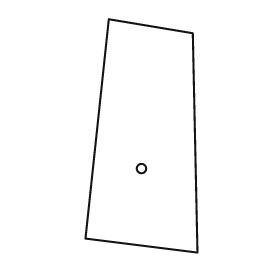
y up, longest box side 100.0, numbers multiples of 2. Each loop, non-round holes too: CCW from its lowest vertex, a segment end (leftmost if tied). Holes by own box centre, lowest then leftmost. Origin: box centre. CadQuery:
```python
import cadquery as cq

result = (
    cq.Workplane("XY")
    .moveTo(24.0, -50.0)
    .lineTo(22.0, 44.0)
    .lineTo(-14.0, 50.0)
    .lineTo(-24.0, -44.0)
    .close()
    .moveTo(0.0, -14.0)
    .circle(2.0)
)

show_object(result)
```